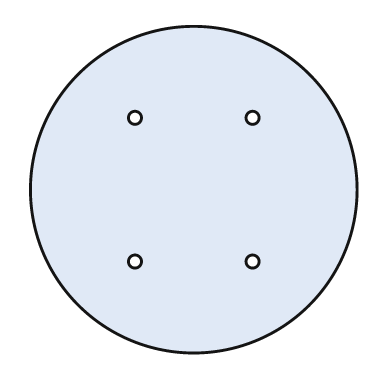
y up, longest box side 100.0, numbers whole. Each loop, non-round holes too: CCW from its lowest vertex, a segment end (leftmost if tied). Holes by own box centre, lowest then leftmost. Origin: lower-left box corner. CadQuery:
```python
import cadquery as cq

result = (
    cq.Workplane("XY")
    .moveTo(50.0, 50.0)
    .circle(50.0)
    .moveTo(32.0, 28.0)
    .circle(2.0)
    .moveTo(68.0, 28.0)
    .circle(2.0)
    .moveTo(32.0, 72.0)
    .circle(2.0)
    .moveTo(68.0, 72.0)
    .circle(2.0)
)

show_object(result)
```